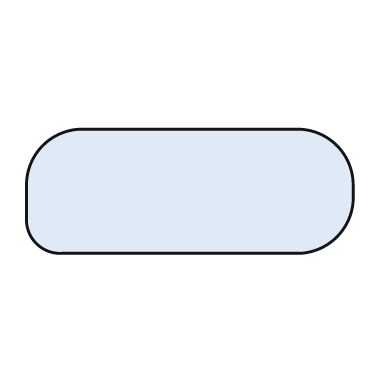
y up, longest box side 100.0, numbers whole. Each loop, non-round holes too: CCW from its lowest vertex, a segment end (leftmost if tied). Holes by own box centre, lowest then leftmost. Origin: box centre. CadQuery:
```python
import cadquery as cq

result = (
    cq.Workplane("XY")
    .moveTo(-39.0, -19.0)
    .lineTo(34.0, -19.0)
    .threePointArc((45.0, -14.0), (50.0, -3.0))
    .lineTo(50.0, 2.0)
    .threePointArc((45.0, 14.0), (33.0, 19.0))
    .lineTo(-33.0, 19.0)
    .threePointArc((-45.0, 14.0), (-50.0, 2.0))
    .lineTo(-50.0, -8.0)
    .threePointArc((-47.0, -16.0), (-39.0, -19.0))
    .close()
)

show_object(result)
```